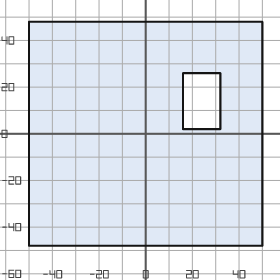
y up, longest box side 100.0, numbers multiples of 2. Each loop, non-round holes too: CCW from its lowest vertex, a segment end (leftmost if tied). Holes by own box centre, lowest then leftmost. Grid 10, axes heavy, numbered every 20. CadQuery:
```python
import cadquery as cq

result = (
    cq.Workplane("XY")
    .moveTo(-50.0, -48.0)
    .lineTo(50.0, -48.0)
    .lineTo(50.0, 48.0)
    .lineTo(-50.0, 48.0)
    .close()
    .moveTo(16.0, 2.0)
    .lineTo(32.0, 2.0)
    .lineTo(32.0, 26.0)
    .lineTo(16.0, 26.0)
    .close()
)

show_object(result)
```